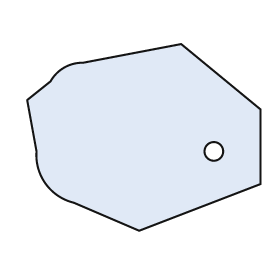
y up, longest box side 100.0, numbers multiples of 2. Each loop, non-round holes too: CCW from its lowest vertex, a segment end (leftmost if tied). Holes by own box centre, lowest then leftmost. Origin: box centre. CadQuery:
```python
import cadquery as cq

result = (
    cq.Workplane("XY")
    .moveTo(-2.0, -40.0)
    .lineTo(50.0, -20.0)
    .lineTo(50.0, 12.0)
    .lineTo(16.0, 40.0)
    .lineTo(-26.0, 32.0)
    .threePointArc((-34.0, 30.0), (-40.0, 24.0))
    .lineTo(-50.0, 16.0)
    .lineTo(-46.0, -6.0)
    .threePointArc((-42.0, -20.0), (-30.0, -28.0))
    .close()
    .moveTo(30.0, -6.0)
    .circle(4.0)
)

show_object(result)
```